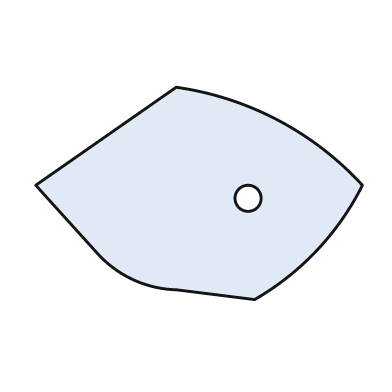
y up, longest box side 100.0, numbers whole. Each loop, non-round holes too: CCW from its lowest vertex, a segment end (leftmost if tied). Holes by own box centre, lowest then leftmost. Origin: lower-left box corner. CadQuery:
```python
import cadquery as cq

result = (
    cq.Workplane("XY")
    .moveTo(67.0, 0.0)
    .threePointArc((86.0, 15.0), (100.0, 35.0))
    .threePointArc((74.0, 55.0), (43.0, 65.0))
    .lineTo(0.0, 35.0)
    .lineTo(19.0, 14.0)
    .threePointArc((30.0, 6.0), (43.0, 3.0))
    .close()
    .moveTo(65.0, 31.0)
    .circle(4.0)
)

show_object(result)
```